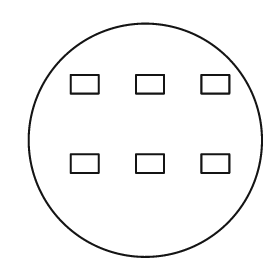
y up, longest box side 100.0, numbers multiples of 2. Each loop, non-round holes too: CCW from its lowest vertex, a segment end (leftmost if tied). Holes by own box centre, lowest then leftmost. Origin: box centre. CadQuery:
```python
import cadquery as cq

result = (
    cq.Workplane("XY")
    .moveTo(0.0, 0.0)
    .circle(50.0)
    .moveTo(-32.0, -14.0)
    .lineTo(-20.0, -14.0)
    .lineTo(-20.0, -6.0)
    .lineTo(-32.0, -6.0)
    .close()
    .moveTo(-4.0, -14.0)
    .lineTo(8.0, -14.0)
    .lineTo(8.0, -6.0)
    .lineTo(-4.0, -6.0)
    .close()
    .moveTo(24.0, -14.0)
    .lineTo(36.0, -14.0)
    .lineTo(36.0, -6.0)
    .lineTo(24.0, -6.0)
    .close()
    .moveTo(-32.0, 20.0)
    .lineTo(-20.0, 20.0)
    .lineTo(-20.0, 28.0)
    .lineTo(-32.0, 28.0)
    .close()
    .moveTo(-4.0, 20.0)
    .lineTo(8.0, 20.0)
    .lineTo(8.0, 28.0)
    .lineTo(-4.0, 28.0)
    .close()
    .moveTo(24.0, 20.0)
    .lineTo(36.0, 20.0)
    .lineTo(36.0, 28.0)
    .lineTo(24.0, 28.0)
    .close()
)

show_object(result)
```